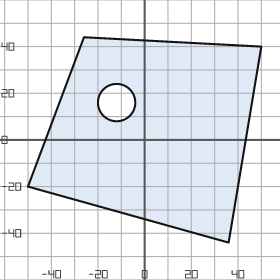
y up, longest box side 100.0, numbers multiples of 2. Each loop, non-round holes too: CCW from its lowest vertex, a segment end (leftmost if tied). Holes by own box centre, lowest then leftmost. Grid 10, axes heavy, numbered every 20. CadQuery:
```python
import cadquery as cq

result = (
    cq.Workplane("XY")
    .moveTo(36.0, -44.0)
    .lineTo(50.0, 40.0)
    .lineTo(-26.0, 44.0)
    .lineTo(-50.0, -20.0)
    .close()
    .moveTo(-12.0, 16.0)
    .circle(8.0)
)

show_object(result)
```